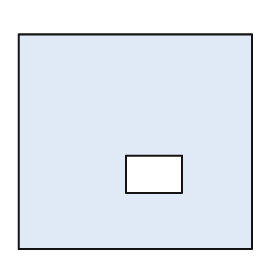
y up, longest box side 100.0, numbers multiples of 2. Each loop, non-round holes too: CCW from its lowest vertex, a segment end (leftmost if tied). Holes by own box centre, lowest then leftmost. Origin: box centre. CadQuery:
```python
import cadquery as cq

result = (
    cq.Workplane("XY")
    .moveTo(-50.0, -46.0)
    .lineTo(50.0, -46.0)
    .lineTo(50.0, 46.0)
    .lineTo(-50.0, 46.0)
    .close()
    .moveTo(-4.0, -22.0)
    .lineTo(20.0, -22.0)
    .lineTo(20.0, -6.0)
    .lineTo(-4.0, -6.0)
    .close()
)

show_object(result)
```